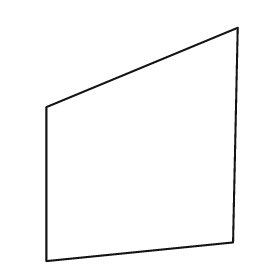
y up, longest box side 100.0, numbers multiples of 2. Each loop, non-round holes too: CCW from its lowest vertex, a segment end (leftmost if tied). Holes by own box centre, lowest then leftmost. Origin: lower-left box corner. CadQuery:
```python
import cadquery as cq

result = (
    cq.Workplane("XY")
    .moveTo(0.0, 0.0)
    .lineTo(80.0, 8.0)
    .lineTo(82.0, 100.0)
    .lineTo(0.0, 66.0)
    .close()
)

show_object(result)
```